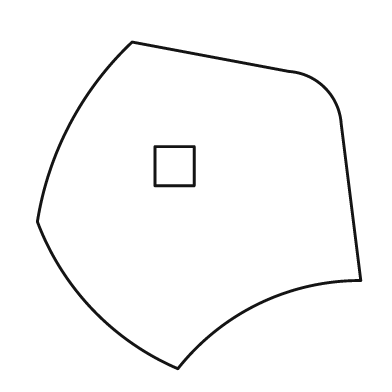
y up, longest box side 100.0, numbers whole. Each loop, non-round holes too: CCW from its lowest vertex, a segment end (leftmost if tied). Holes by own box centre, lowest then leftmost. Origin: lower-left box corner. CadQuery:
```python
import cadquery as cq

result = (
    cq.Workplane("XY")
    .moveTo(43.0, 0.0)
    .threePointArc((68.0, 20.0), (99.0, 27.0))
    .lineTo(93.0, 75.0)
    .threePointArc((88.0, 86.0), (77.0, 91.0))
    .lineTo(29.0, 100.0)
    .threePointArc((10.0, 75.0), (0.0, 45.0))
    .threePointArc((17.0, 18.0), (43.0, 0.0))
    .close()
    .moveTo(36.0, 56.0)
    .lineTo(48.0, 56.0)
    .lineTo(48.0, 68.0)
    .lineTo(36.0, 68.0)
    .close()
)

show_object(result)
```